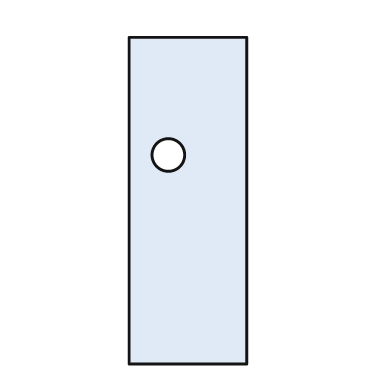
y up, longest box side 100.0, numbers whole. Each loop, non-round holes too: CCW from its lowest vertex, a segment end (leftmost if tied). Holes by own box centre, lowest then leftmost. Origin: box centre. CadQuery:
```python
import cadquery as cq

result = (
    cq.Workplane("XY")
    .moveTo(-18.0, -50.0)
    .lineTo(18.0, -50.0)
    .lineTo(18.0, 50.0)
    .lineTo(-18.0, 50.0)
    .close()
    .moveTo(-6.0, 14.0)
    .circle(5.0)
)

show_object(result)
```